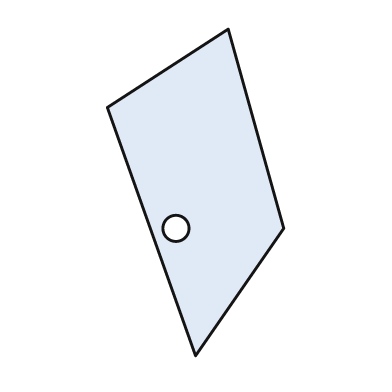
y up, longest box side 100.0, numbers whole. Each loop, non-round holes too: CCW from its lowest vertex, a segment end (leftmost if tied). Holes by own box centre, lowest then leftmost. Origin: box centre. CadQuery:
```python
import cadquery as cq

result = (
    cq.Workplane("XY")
    .moveTo(0.0, -50.0)
    .lineTo(27.0, -11.0)
    .lineTo(10.0, 50.0)
    .lineTo(-27.0, 26.0)
    .close()
    .moveTo(-6.0, -11.0)
    .circle(4.0)
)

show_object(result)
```